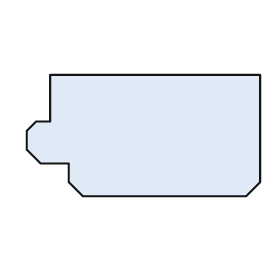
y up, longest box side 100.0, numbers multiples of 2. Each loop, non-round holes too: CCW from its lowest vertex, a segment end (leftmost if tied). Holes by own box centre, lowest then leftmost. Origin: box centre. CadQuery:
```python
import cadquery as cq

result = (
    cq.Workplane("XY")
    .moveTo(-26.0, -26.0)
    .lineTo(44.0, -26.0)
    .lineTo(50.0, -20.0)
    .lineTo(50.0, 26.0)
    .lineTo(-40.0, 26.0)
    .lineTo(-40.0, 6.0)
    .lineTo(-46.0, 6.0)
    .lineTo(-50.0, 2.0)
    .lineTo(-50.0, -6.0)
    .lineTo(-44.0, -12.0)
    .lineTo(-32.0, -12.0)
    .lineTo(-32.0, -20.0)
    .close()
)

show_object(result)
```